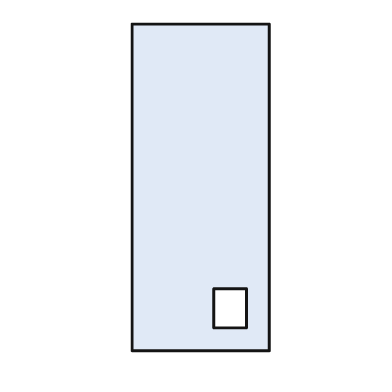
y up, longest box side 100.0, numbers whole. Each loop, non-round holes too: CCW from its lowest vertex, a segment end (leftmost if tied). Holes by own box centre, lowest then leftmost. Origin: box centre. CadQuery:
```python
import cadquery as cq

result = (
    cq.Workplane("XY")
    .moveTo(-21.0, -50.0)
    .lineTo(21.0, -50.0)
    .lineTo(21.0, 50.0)
    .lineTo(-21.0, 50.0)
    .close()
    .moveTo(4.0, -43.0)
    .lineTo(14.0, -43.0)
    .lineTo(14.0, -31.0)
    .lineTo(4.0, -31.0)
    .close()
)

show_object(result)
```